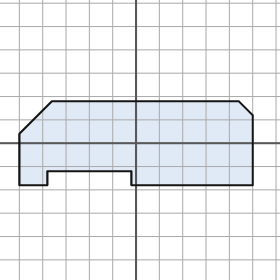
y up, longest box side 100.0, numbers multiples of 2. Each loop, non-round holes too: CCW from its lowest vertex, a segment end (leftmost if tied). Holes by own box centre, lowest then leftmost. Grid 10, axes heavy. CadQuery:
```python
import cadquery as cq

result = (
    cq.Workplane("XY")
    .moveTo(-50.0, -18.0)
    .lineTo(-38.0, -18.0)
    .lineTo(-38.0, -12.0)
    .lineTo(-2.0, -12.0)
    .lineTo(-2.0, -18.0)
    .lineTo(50.0, -18.0)
    .lineTo(50.0, 12.0)
    .lineTo(44.0, 18.0)
    .lineTo(-36.0, 18.0)
    .lineTo(-50.0, 4.0)
    .close()
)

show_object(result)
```